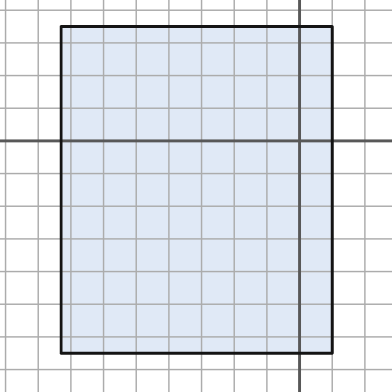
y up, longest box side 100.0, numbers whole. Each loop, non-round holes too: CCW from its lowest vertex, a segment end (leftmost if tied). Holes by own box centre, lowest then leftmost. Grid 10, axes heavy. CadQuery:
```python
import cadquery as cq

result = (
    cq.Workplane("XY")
    .moveTo(-73.0, -65.0)
    .lineTo(10.0, -65.0)
    .lineTo(10.0, 35.0)
    .lineTo(-73.0, 35.0)
    .close()
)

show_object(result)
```